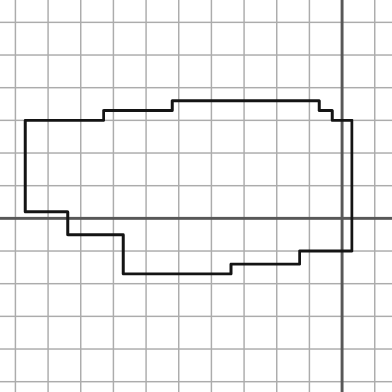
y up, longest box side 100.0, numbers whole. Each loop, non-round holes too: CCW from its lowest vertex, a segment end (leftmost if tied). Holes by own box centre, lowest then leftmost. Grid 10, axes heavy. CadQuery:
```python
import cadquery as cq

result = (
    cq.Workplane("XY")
    .moveTo(-67.0, -17.0)
    .lineTo(-34.0, -17.0)
    .lineTo(-34.0, -14.0)
    .lineTo(-13.0, -14.0)
    .lineTo(-13.0, -10.0)
    .lineTo(3.0, -10.0)
    .lineTo(3.0, 30.0)
    .lineTo(-3.0, 30.0)
    .lineTo(-3.0, 33.0)
    .lineTo(-7.0, 33.0)
    .lineTo(-7.0, 36.0)
    .lineTo(-52.0, 36.0)
    .lineTo(-52.0, 33.0)
    .lineTo(-73.0, 33.0)
    .lineTo(-73.0, 30.0)
    .lineTo(-97.0, 30.0)
    .lineTo(-97.0, 2.0)
    .lineTo(-84.0, 2.0)
    .lineTo(-84.0, -5.0)
    .lineTo(-67.0, -5.0)
    .close()
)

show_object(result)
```